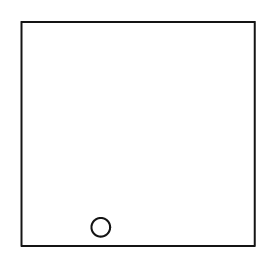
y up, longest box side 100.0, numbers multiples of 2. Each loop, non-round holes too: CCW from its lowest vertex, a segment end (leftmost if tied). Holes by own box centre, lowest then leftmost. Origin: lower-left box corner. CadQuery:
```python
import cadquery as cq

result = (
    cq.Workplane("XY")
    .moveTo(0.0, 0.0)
    .lineTo(100.0, 0.0)
    .lineTo(100.0, 96.0)
    .lineTo(0.0, 96.0)
    .close()
    .moveTo(34.0, 8.0)
    .circle(4.0)
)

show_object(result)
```